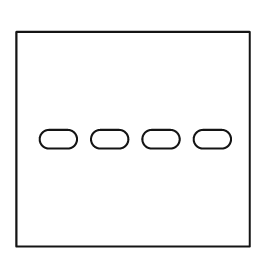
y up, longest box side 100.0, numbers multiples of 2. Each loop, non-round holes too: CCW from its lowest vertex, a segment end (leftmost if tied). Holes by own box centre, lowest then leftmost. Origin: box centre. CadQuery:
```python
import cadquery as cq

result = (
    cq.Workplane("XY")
    .moveTo(-50.0, -46.0)
    .lineTo(50.0, -46.0)
    .lineTo(50.0, 46.0)
    .lineTo(-50.0, 46.0)
    .close()
    .moveTo(-36.0, -4.0)
    .lineTo(-28.0, -4.0)
    .threePointArc((-24.0, 0.0), (-28.0, 4.0))
    .lineTo(-36.0, 4.0)
    .threePointArc((-40.0, 0.0), (-36.0, -4.0))
    .close()
    .moveTo(-14.0, -4.0)
    .lineTo(-6.0, -4.0)
    .threePointArc((-2.0, 0.0), (-6.0, 4.0))
    .lineTo(-14.0, 4.0)
    .threePointArc((-18.0, 0.0), (-14.0, -4.0))
    .close()
    .moveTo(8.0, -4.0)
    .lineTo(16.0, -4.0)
    .threePointArc((20.0, 0.0), (16.0, 4.0))
    .lineTo(8.0, 4.0)
    .threePointArc((4.0, 0.0), (8.0, -4.0))
    .close()
    .moveTo(30.0, -4.0)
    .lineTo(38.0, -4.0)
    .threePointArc((42.0, 0.0), (38.0, 4.0))
    .lineTo(30.0, 4.0)
    .threePointArc((26.0, 0.0), (30.0, -4.0))
    .close()
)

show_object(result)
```